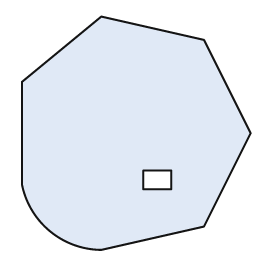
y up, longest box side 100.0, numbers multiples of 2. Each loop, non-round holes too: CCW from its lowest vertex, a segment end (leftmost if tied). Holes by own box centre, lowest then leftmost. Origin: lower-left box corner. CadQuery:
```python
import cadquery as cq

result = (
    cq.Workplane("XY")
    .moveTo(34.0, 0.0)
    .lineTo(78.0, 10.0)
    .lineTo(98.0, 50.0)
    .lineTo(78.0, 90.0)
    .lineTo(34.0, 100.0)
    .lineTo(0.0, 72.0)
    .lineTo(0.0, 28.0)
    .threePointArc((12.0, 8.0), (34.0, 0.0))
    .close()
    .moveTo(52.0, 26.0)
    .lineTo(64.0, 26.0)
    .lineTo(64.0, 34.0)
    .lineTo(52.0, 34.0)
    .close()
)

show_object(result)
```